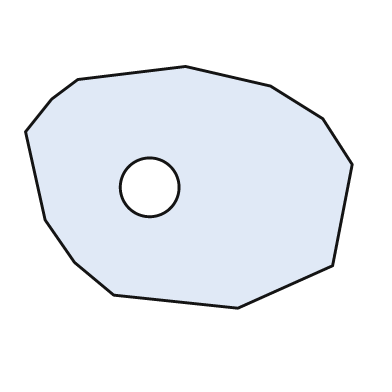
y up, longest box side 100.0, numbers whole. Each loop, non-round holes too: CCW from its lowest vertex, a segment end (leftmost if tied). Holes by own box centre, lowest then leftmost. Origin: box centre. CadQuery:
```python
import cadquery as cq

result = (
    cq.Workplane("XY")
    .moveTo(15.0, -37.0)
    .lineTo(44.0, -24.0)
    .lineTo(50.0, 7.0)
    .lineTo(41.0, 21.0)
    .lineTo(25.0, 31.0)
    .lineTo(-1.0, 37.0)
    .lineTo(-34.0, 33.0)
    .lineTo(-42.0, 27.0)
    .lineTo(-50.0, 17.0)
    .lineTo(-44.0, -10.0)
    .lineTo(-35.0, -23.0)
    .lineTo(-23.0, -33.0)
    .close()
    .moveTo(-12.0, 0.0)
    .circle(9.0)
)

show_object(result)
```